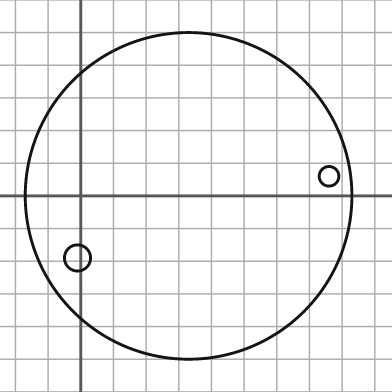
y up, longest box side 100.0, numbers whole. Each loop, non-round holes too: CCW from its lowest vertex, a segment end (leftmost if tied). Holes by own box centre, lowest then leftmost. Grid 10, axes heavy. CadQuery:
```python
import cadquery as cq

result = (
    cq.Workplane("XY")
    .moveTo(33.0, 0.0)
    .circle(50.0)
    .moveTo(-1.0, -19.0)
    .circle(4.0)
    .moveTo(76.0, 6.0)
    .circle(3.0)
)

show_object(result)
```